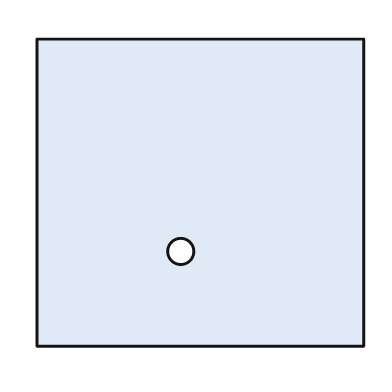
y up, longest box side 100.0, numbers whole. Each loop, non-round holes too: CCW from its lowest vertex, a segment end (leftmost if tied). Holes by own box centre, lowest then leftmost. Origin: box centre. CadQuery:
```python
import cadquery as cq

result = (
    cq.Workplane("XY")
    .moveTo(-50.0, -47.0)
    .lineTo(50.0, -47.0)
    .lineTo(50.0, 47.0)
    .lineTo(-50.0, 47.0)
    .close()
    .moveTo(-6.0, -18.0)
    .circle(4.0)
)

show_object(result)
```